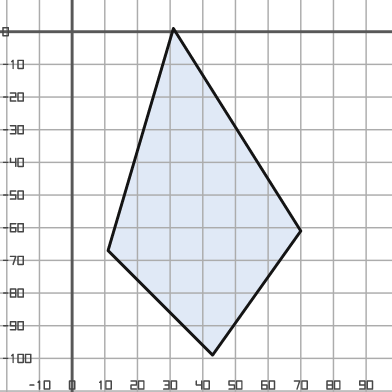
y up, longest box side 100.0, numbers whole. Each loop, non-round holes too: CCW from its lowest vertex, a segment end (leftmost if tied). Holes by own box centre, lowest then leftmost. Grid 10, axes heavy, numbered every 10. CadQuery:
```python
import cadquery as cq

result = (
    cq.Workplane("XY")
    .moveTo(43.0, -99.0)
    .lineTo(70.0, -61.0)
    .lineTo(31.0, 1.0)
    .lineTo(11.0, -67.0)
    .close()
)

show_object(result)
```